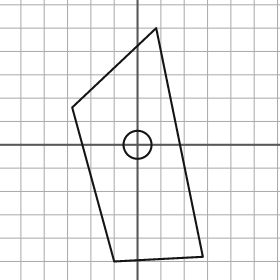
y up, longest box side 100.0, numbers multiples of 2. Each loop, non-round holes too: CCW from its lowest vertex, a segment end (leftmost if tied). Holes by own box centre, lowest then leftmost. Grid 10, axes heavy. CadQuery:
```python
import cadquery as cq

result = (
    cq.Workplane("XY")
    .moveTo(-10.0, -50.0)
    .lineTo(28.0, -48.0)
    .lineTo(8.0, 50.0)
    .lineTo(-28.0, 16.0)
    .close()
    .moveTo(0.0, 0.0)
    .circle(6.0)
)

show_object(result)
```